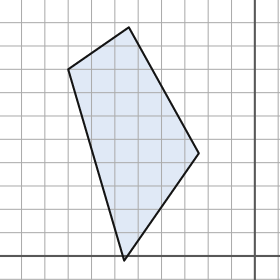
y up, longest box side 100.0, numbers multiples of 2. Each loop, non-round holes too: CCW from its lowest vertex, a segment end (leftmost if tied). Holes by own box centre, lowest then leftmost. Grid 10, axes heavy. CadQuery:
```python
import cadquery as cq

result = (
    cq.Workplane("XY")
    .moveTo(-56.0, -2.0)
    .lineTo(-24.0, 44.0)
    .lineTo(-54.0, 98.0)
    .lineTo(-80.0, 80.0)
    .close()
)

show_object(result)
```